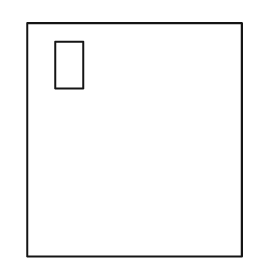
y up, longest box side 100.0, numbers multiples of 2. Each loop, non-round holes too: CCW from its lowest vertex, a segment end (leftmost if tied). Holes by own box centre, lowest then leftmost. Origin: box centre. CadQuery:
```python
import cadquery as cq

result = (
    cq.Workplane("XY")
    .moveTo(-46.0, -50.0)
    .lineTo(46.0, -50.0)
    .lineTo(46.0, 50.0)
    .lineTo(-46.0, 50.0)
    .close()
    .moveTo(-34.0, 22.0)
    .lineTo(-22.0, 22.0)
    .lineTo(-22.0, 42.0)
    .lineTo(-34.0, 42.0)
    .close()
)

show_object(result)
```